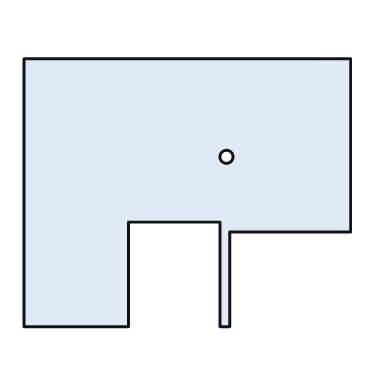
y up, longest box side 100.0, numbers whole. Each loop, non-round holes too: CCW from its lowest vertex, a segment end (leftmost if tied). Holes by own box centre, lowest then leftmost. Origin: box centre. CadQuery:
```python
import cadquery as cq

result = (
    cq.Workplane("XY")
    .moveTo(-50.0, -41.0)
    .lineTo(-18.0, -41.0)
    .lineTo(-18.0, -9.0)
    .lineTo(10.0, -9.0)
    .lineTo(10.0, -41.0)
    .lineTo(13.0, -41.0)
    .lineTo(13.0, -12.0)
    .lineTo(50.0, -12.0)
    .lineTo(50.0, 41.0)
    .lineTo(-50.0, 41.0)
    .close()
    .moveTo(12.0, 11.0)
    .circle(2.0)
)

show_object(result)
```